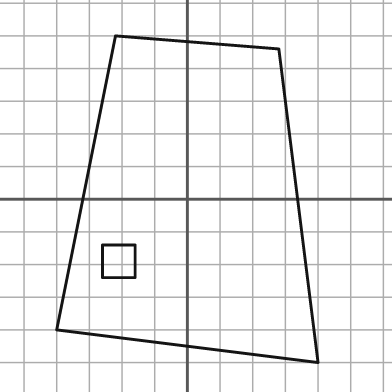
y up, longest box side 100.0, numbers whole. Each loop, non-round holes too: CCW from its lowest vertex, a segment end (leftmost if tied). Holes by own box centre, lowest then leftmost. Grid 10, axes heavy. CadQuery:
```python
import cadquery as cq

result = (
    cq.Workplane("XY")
    .moveTo(40.0, -50.0)
    .lineTo(28.0, 46.0)
    .lineTo(-22.0, 50.0)
    .lineTo(-40.0, -40.0)
    .close()
    .moveTo(-26.0, -24.0)
    .lineTo(-16.0, -24.0)
    .lineTo(-16.0, -14.0)
    .lineTo(-26.0, -14.0)
    .close()
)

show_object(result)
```